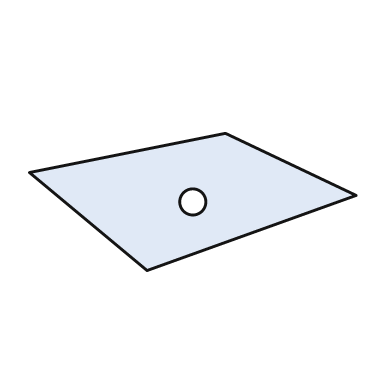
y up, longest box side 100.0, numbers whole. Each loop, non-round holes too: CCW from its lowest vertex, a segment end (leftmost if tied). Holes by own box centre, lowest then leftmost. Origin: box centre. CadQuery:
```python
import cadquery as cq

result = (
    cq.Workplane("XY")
    .moveTo(-14.0, -21.0)
    .lineTo(50.0, 2.0)
    .lineTo(10.0, 21.0)
    .lineTo(-50.0, 9.0)
    .close()
    .moveTo(0.0, 0.0)
    .circle(4.0)
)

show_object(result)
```